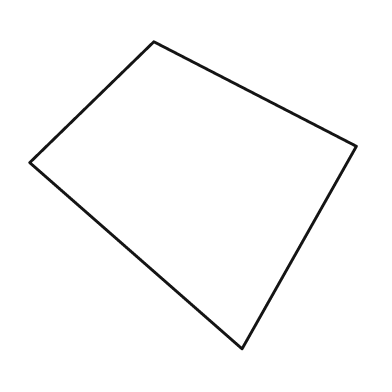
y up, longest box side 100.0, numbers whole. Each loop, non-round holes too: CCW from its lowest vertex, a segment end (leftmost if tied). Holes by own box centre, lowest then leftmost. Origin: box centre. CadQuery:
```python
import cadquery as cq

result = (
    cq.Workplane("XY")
    .moveTo(15.0, -47.0)
    .lineTo(50.0, 15.0)
    .lineTo(-12.0, 47.0)
    .lineTo(-50.0, 10.0)
    .close()
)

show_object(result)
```